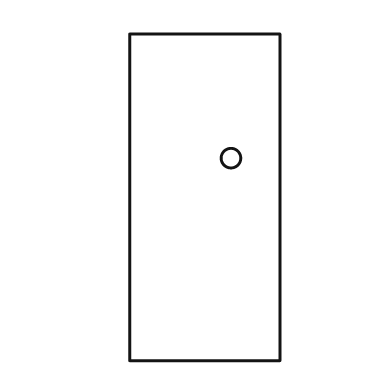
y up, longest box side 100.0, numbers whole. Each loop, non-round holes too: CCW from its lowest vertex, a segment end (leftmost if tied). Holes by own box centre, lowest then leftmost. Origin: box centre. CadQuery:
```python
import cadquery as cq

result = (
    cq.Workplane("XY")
    .moveTo(-23.0, -50.0)
    .lineTo(23.0, -50.0)
    .lineTo(23.0, 50.0)
    .lineTo(-23.0, 50.0)
    .close()
    .moveTo(8.0, 12.0)
    .circle(3.0)
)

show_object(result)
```